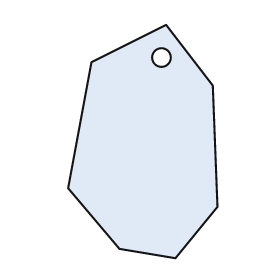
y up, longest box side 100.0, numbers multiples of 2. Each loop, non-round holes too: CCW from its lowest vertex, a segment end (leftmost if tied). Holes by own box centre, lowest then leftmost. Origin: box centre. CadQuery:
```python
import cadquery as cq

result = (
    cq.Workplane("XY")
    .moveTo(14.0, -50.0)
    .lineTo(32.0, -28.0)
    .lineTo(30.0, 24.0)
    .lineTo(10.0, 50.0)
    .lineTo(-22.0, 34.0)
    .lineTo(-32.0, -20.0)
    .lineTo(-10.0, -46.0)
    .close()
    .moveTo(8.0, 36.0)
    .circle(4.0)
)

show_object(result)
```